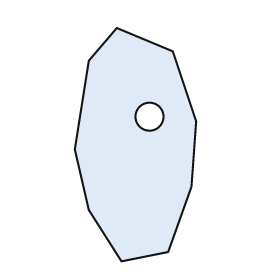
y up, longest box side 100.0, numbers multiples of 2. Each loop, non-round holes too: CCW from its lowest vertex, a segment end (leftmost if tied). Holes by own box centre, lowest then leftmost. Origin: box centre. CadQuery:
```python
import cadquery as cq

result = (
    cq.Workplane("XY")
    .moveTo(-6.0, -50.0)
    .lineTo(14.0, -46.0)
    .lineTo(24.0, -18.0)
    .lineTo(26.0, 10.0)
    .lineTo(16.0, 40.0)
    .lineTo(-8.0, 50.0)
    .lineTo(-20.0, 36.0)
    .lineTo(-26.0, -2.0)
    .lineTo(-20.0, -28.0)
    .close()
    .moveTo(6.0, 12.0)
    .circle(6.0)
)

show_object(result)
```